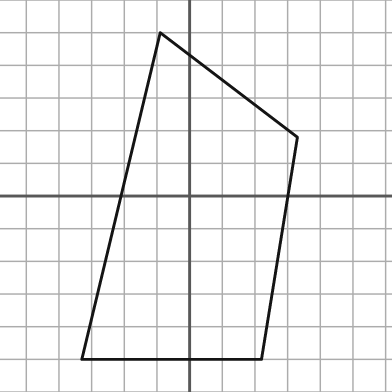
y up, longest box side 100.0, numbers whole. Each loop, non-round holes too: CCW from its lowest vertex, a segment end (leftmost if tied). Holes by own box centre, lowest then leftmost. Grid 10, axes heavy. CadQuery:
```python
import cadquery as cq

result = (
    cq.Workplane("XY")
    .moveTo(-33.0, -50.0)
    .lineTo(22.0, -50.0)
    .lineTo(33.0, 18.0)
    .lineTo(-9.0, 50.0)
    .close()
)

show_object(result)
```